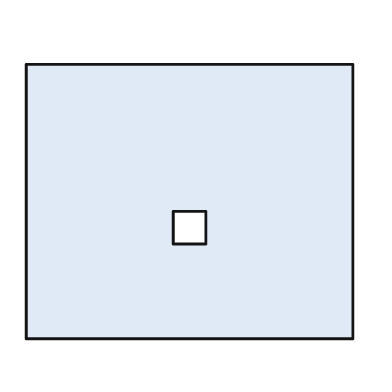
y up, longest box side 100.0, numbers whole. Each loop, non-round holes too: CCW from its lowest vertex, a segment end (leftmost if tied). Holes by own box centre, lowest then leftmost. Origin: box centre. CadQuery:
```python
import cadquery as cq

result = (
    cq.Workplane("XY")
    .moveTo(-50.0, -42.0)
    .lineTo(50.0, -42.0)
    .lineTo(50.0, 42.0)
    .lineTo(-50.0, 42.0)
    .close()
    .moveTo(-5.0, -13.0)
    .lineTo(5.0, -13.0)
    .lineTo(5.0, -3.0)
    .lineTo(-5.0, -3.0)
    .close()
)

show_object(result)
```